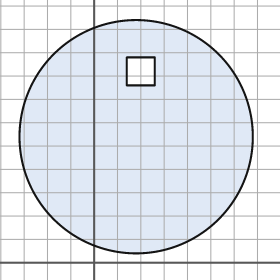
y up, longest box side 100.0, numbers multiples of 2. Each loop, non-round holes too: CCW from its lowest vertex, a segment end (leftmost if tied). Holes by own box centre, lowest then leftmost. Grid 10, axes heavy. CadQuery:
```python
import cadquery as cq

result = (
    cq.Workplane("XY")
    .moveTo(18.0, 54.0)
    .circle(50.0)
    .moveTo(14.0, 76.0)
    .lineTo(26.0, 76.0)
    .lineTo(26.0, 88.0)
    .lineTo(14.0, 88.0)
    .close()
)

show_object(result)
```